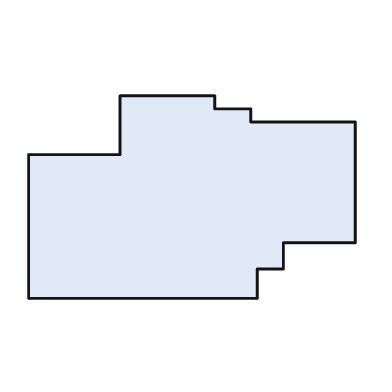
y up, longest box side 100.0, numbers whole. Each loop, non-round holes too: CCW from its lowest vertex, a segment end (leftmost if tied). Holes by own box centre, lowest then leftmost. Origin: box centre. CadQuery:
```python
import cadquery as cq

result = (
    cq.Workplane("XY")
    .moveTo(-50.0, -31.0)
    .lineTo(20.0, -31.0)
    .lineTo(20.0, -22.0)
    .lineTo(28.0, -22.0)
    .lineTo(28.0, -14.0)
    .lineTo(50.0, -14.0)
    .lineTo(50.0, 23.0)
    .lineTo(18.0, 23.0)
    .lineTo(18.0, 27.0)
    .lineTo(7.0, 27.0)
    .lineTo(7.0, 31.0)
    .lineTo(-22.0, 31.0)
    .lineTo(-22.0, 13.0)
    .lineTo(-50.0, 13.0)
    .close()
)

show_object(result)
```